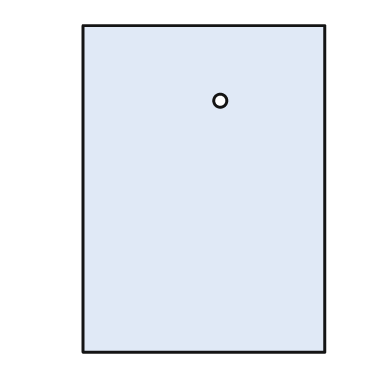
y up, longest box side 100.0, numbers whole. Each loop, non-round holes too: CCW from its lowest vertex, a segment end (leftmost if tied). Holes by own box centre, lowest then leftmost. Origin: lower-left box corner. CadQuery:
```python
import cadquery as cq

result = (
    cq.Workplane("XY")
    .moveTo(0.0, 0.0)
    .lineTo(74.0, 0.0)
    .lineTo(74.0, 100.0)
    .lineTo(0.0, 100.0)
    .close()
    .moveTo(42.0, 77.0)
    .circle(2.0)
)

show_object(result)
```